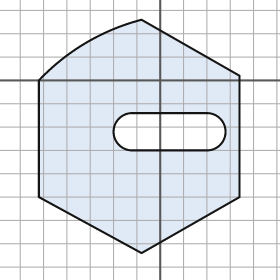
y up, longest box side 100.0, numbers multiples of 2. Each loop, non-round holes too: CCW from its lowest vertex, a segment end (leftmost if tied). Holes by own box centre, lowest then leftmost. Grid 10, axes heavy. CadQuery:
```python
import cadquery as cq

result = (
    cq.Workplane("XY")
    .moveTo(-8.0, -74.0)
    .lineTo(34.0, -50.0)
    .lineTo(34.0, 2.0)
    .lineTo(-8.0, 26.0)
    .threePointArc((-32.0, 16.0), (-52.0, 0.0))
    .lineTo(-52.0, -50.0)
    .close()
    .moveTo(-12.0, -30.0)
    .lineTo(20.0, -30.0)
    .threePointArc((28.0, -22.0), (20.0, -14.0))
    .lineTo(-12.0, -14.0)
    .threePointArc((-20.0, -22.0), (-12.0, -30.0))
    .close()
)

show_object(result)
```